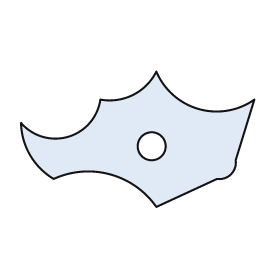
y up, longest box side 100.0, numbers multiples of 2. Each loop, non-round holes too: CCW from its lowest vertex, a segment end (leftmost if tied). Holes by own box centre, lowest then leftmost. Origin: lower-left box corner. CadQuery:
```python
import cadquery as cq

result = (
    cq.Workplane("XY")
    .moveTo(58.0, 0.0)
    .lineTo(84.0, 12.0)
    .threePointArc((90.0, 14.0), (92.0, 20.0))
    .lineTo(100.0, 46.0)
    .threePointArc((76.0, 42.0), (58.0, 58.0))
    .threePointArc((48.0, 48.0), (34.0, 46.0))
    .threePointArc((20.0, 30.0), (0.0, 36.0))
    .threePointArc((4.0, 22.0), (14.0, 12.0))
    .threePointArc((38.0, 14.0), (58.0, 0.0))
    .close()
    .moveTo(56.0, 26.0)
    .circle(6.0)
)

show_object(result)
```